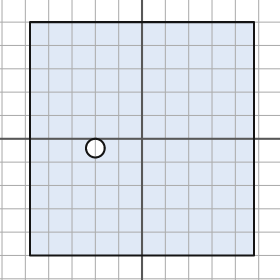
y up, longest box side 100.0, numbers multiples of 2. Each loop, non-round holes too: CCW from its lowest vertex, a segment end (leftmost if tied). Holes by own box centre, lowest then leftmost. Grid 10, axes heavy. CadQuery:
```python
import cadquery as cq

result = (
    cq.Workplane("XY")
    .moveTo(-48.0, -50.0)
    .lineTo(48.0, -50.0)
    .lineTo(48.0, 50.0)
    .lineTo(-48.0, 50.0)
    .close()
    .moveTo(-20.0, -4.0)
    .circle(4.0)
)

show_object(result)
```